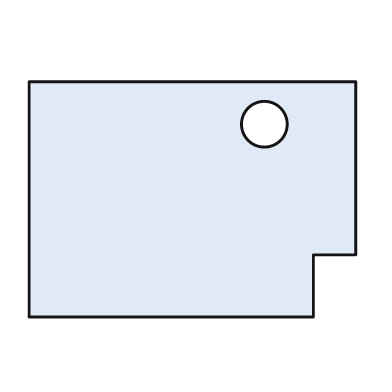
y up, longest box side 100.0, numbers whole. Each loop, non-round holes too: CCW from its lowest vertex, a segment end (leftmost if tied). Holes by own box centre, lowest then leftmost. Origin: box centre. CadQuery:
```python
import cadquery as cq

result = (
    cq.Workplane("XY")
    .moveTo(-50.0, -36.0)
    .lineTo(37.0, -36.0)
    .lineTo(37.0, -17.0)
    .lineTo(50.0, -17.0)
    .lineTo(50.0, 36.0)
    .lineTo(-50.0, 36.0)
    .close()
    .moveTo(22.0, 23.0)
    .circle(7.0)
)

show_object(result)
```